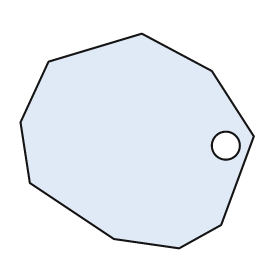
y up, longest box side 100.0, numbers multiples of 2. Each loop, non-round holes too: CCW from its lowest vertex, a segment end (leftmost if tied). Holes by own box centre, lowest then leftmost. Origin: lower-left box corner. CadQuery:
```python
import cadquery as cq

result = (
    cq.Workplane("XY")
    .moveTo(68.0, 0.0)
    .lineTo(86.0, 10.0)
    .lineTo(100.0, 48.0)
    .lineTo(82.0, 76.0)
    .lineTo(52.0, 92.0)
    .lineTo(12.0, 80.0)
    .lineTo(0.0, 54.0)
    .lineTo(4.0, 28.0)
    .lineTo(40.0, 4.0)
    .close()
    .moveTo(88.0, 44.0)
    .circle(6.0)
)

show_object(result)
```